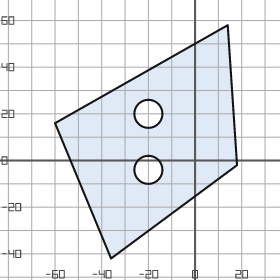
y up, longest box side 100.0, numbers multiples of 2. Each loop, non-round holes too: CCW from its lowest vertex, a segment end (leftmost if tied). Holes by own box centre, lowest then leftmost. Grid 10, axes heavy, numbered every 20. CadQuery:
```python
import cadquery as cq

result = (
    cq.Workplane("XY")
    .moveTo(-36.0, -42.0)
    .lineTo(18.0, -2.0)
    .lineTo(14.0, 58.0)
    .lineTo(-60.0, 16.0)
    .close()
    .moveTo(-20.0, -4.0)
    .circle(6.0)
    .moveTo(-20.0, 20.0)
    .circle(6.0)
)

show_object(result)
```